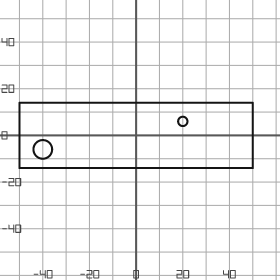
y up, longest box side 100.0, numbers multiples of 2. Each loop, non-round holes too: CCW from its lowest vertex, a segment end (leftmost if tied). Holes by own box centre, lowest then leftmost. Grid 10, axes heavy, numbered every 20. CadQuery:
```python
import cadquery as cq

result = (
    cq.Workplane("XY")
    .moveTo(-50.0, -14.0)
    .lineTo(50.0, -14.0)
    .lineTo(50.0, 14.0)
    .lineTo(-50.0, 14.0)
    .close()
    .moveTo(-40.0, -6.0)
    .circle(4.0)
    .moveTo(20.0, 6.0)
    .circle(2.0)
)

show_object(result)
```